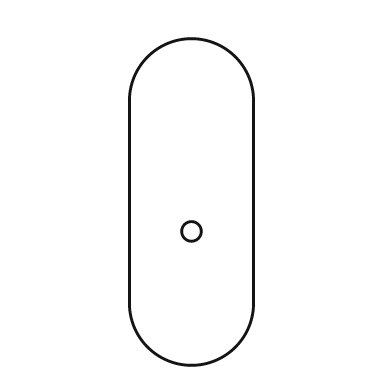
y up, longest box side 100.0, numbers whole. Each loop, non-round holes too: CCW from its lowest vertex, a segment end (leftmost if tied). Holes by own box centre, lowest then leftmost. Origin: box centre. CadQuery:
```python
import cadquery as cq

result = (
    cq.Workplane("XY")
    .moveTo(-19.0, -31.0)
    .threePointArc((0.0, -50.0), (19.0, -31.0))
    .lineTo(19.0, 31.0)
    .threePointArc((0.0, 50.0), (-19.0, 31.0))
    .close()
    .moveTo(0.0, -9.0)
    .circle(3.0)
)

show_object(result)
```